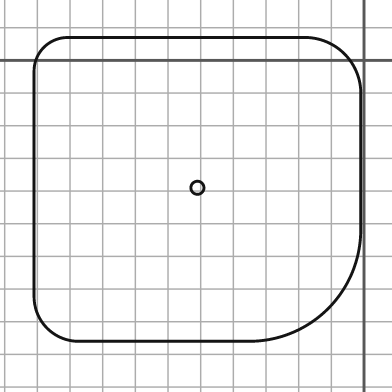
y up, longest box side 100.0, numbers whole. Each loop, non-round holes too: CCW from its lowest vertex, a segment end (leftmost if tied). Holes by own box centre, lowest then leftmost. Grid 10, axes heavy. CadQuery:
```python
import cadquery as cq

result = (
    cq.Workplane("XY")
    .moveTo(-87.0, -86.0)
    .lineTo(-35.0, -86.0)
    .threePointArc((-11.0, -76.0), (-1.0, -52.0))
    .lineTo(-1.0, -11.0)
    .threePointArc((-6.0, 2.0), (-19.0, 7.0))
    .lineTo(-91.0, 7.0)
    .threePointArc((-98.0, 4.0), (-101.0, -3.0))
    .lineTo(-101.0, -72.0)
    .threePointArc((-97.0, -82.0), (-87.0, -86.0))
    .close()
    .moveTo(-51.0, -39.0)
    .circle(2.0)
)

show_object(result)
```